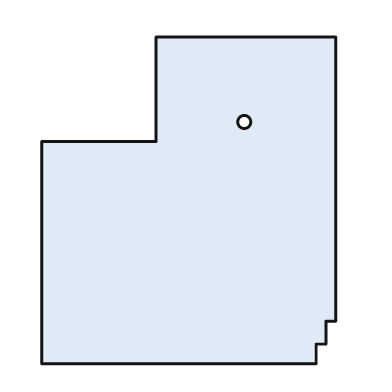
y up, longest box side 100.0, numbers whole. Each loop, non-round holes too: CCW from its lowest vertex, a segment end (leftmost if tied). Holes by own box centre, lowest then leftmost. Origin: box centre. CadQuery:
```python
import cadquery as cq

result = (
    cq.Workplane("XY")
    .moveTo(-45.0, -50.0)
    .lineTo(39.0, -50.0)
    .lineTo(39.0, -44.0)
    .lineTo(42.0, -44.0)
    .lineTo(42.0, -37.0)
    .lineTo(45.0, -37.0)
    .lineTo(45.0, 50.0)
    .lineTo(-10.0, 50.0)
    .lineTo(-10.0, 18.0)
    .lineTo(-45.0, 18.0)
    .close()
    .moveTo(17.0, 24.0)
    .circle(2.0)
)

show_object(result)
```